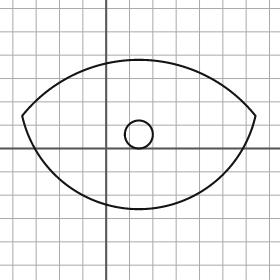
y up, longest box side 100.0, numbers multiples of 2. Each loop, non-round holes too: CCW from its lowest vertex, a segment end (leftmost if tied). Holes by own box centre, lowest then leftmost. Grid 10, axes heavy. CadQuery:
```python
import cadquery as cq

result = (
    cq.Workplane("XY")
    .moveTo(-36.0, 14.0)
    .threePointArc((14.0, -26.0), (64.0, 14.0))
    .threePointArc((14.0, 38.0), (-36.0, 14.0))
    .close()
    .moveTo(14.0, 6.0)
    .circle(6.0)
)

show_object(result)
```